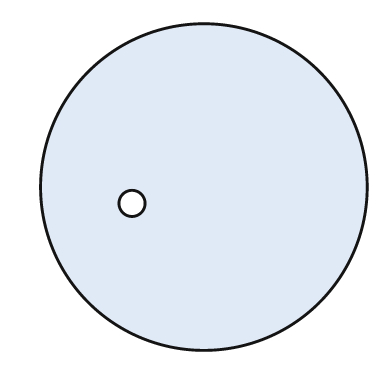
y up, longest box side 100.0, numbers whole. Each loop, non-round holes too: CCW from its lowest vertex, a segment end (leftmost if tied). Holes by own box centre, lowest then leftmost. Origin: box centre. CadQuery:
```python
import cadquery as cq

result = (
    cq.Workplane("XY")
    .moveTo(0.0, 0.0)
    .circle(50.0)
    .moveTo(-22.0, -5.0)
    .circle(4.0)
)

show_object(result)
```